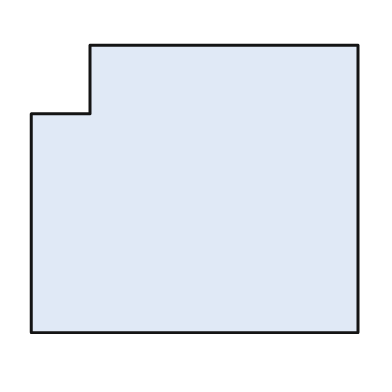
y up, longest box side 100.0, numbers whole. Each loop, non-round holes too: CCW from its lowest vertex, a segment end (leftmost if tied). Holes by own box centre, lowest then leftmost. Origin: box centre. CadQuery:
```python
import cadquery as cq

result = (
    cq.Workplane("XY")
    .moveTo(-50.0, -44.0)
    .lineTo(50.0, -44.0)
    .lineTo(50.0, 44.0)
    .lineTo(-32.0, 44.0)
    .lineTo(-32.0, 23.0)
    .lineTo(-50.0, 23.0)
    .close()
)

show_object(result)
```